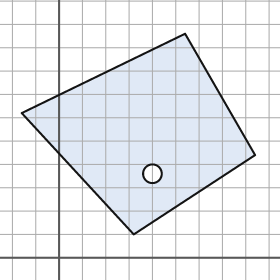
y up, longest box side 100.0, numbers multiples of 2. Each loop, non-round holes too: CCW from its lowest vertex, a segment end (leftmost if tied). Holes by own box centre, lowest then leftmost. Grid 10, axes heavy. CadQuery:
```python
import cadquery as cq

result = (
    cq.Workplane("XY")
    .moveTo(32.0, 10.0)
    .lineTo(84.0, 44.0)
    .lineTo(54.0, 96.0)
    .lineTo(-16.0, 62.0)
    .close()
    .moveTo(40.0, 36.0)
    .circle(4.0)
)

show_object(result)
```